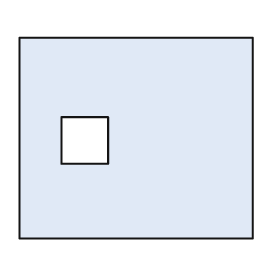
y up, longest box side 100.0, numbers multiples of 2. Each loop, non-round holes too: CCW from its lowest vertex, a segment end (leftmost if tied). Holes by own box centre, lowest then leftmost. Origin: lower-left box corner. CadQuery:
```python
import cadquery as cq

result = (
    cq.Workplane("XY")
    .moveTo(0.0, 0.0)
    .lineTo(100.0, 0.0)
    .lineTo(100.0, 86.0)
    .lineTo(0.0, 86.0)
    .close()
    .moveTo(18.0, 32.0)
    .lineTo(38.0, 32.0)
    .lineTo(38.0, 52.0)
    .lineTo(18.0, 52.0)
    .close()
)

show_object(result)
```